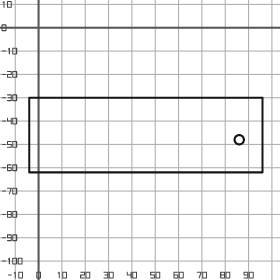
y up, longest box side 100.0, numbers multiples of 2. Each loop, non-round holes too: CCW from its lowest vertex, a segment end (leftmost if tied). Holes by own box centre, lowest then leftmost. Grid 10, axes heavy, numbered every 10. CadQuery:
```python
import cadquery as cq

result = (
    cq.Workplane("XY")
    .moveTo(-4.0, -62.0)
    .lineTo(96.0, -62.0)
    .lineTo(96.0, -30.0)
    .lineTo(-4.0, -30.0)
    .close()
    .moveTo(86.0, -48.0)
    .circle(2.0)
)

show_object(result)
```